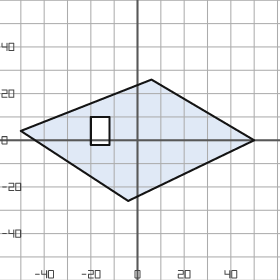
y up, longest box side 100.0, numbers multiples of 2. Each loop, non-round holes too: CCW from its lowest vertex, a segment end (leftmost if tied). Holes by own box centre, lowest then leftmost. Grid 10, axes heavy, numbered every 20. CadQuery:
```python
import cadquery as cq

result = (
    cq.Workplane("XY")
    .moveTo(-4.0, -26.0)
    .lineTo(50.0, 0.0)
    .lineTo(6.0, 26.0)
    .lineTo(-50.0, 4.0)
    .close()
    .moveTo(-20.0, -2.0)
    .lineTo(-12.0, -2.0)
    .lineTo(-12.0, 10.0)
    .lineTo(-20.0, 10.0)
    .close()
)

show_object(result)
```